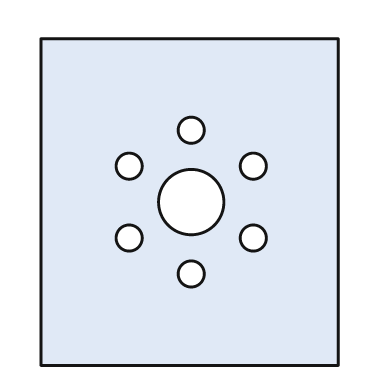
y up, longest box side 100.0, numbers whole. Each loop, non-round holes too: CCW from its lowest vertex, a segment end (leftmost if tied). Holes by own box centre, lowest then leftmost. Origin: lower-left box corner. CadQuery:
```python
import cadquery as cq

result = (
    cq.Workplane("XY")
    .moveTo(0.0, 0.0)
    .lineTo(91.0, 0.0)
    .lineTo(91.0, 100.0)
    .lineTo(0.0, 100.0)
    .close()
    .moveTo(46.0, 28.0)
    .circle(4.0)
    .moveTo(27.0, 39.0)
    .circle(4.0)
    .moveTo(65.0, 39.0)
    .circle(4.0)
    .moveTo(46.0, 50.0)
    .circle(10.0)
    .moveTo(27.0, 61.0)
    .circle(4.0)
    .moveTo(65.0, 61.0)
    .circle(4.0)
    .moveTo(46.0, 72.0)
    .circle(4.0)
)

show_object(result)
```